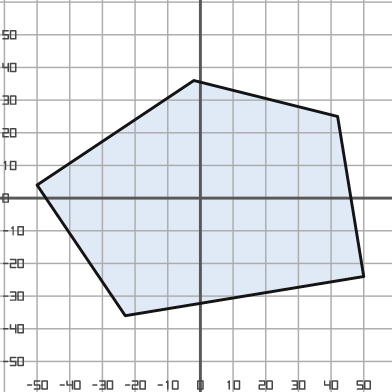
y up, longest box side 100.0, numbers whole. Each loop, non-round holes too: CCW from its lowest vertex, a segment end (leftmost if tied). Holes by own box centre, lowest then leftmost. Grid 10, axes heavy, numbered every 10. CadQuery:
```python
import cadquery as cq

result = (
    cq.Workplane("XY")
    .moveTo(-23.0, -36.0)
    .lineTo(50.0, -24.0)
    .lineTo(42.0, 25.0)
    .lineTo(-2.0, 36.0)
    .lineTo(-50.0, 4.0)
    .close()
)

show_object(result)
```